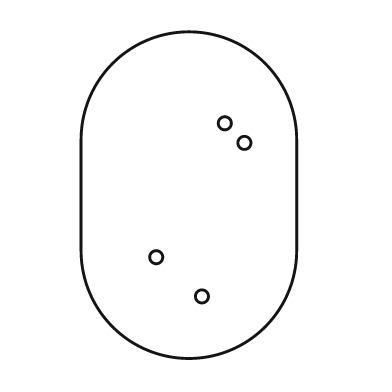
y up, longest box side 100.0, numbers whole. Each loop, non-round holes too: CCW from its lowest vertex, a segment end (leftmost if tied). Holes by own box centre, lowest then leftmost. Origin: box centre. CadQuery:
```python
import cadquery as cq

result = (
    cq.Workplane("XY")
    .moveTo(-33.0, -17.0)
    .threePointArc((0.0, -50.0), (33.0, -17.0))
    .lineTo(33.0, 17.0)
    .threePointArc((0.0, 50.0), (-33.0, 17.0))
    .close()
    .moveTo(4.0, -31.0)
    .circle(2.0)
    .moveTo(-10.0, -19.0)
    .circle(2.0)
    .moveTo(17.0, 16.0)
    .circle(2.0)
    .moveTo(11.0, 22.0)
    .circle(2.0)
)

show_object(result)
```